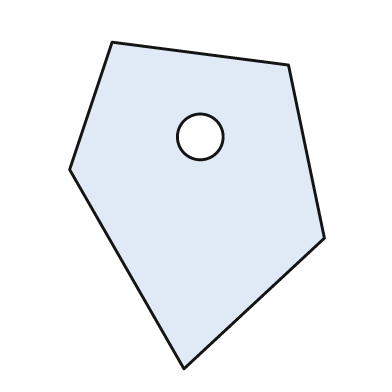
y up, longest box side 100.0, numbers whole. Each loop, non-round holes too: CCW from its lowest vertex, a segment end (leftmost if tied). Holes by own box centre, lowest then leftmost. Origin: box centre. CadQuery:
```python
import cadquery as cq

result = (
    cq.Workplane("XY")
    .moveTo(-4.0, -50.0)
    .lineTo(39.0, -10.0)
    .lineTo(28.0, 43.0)
    .lineTo(-26.0, 50.0)
    .lineTo(-39.0, 11.0)
    .close()
    .moveTo(1.0, 21.0)
    .circle(7.0)
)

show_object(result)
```